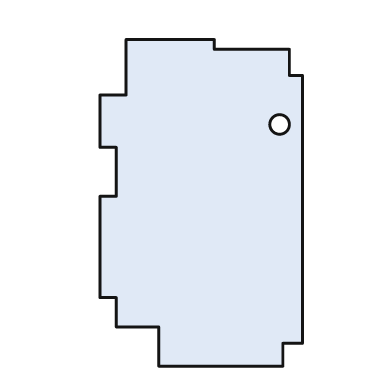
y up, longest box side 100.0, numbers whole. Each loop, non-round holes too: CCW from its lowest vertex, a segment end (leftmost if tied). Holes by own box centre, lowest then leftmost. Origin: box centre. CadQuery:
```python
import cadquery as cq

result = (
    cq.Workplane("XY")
    .moveTo(-13.0, -50.0)
    .lineTo(25.0, -50.0)
    .lineTo(25.0, -43.0)
    .lineTo(31.0, -43.0)
    .lineTo(31.0, 39.0)
    .lineTo(27.0, 39.0)
    .lineTo(27.0, 47.0)
    .lineTo(4.0, 47.0)
    .lineTo(4.0, 50.0)
    .lineTo(-23.0, 50.0)
    .lineTo(-23.0, 33.0)
    .lineTo(-31.0, 33.0)
    .lineTo(-31.0, 17.0)
    .lineTo(-26.0, 17.0)
    .lineTo(-26.0, 2.0)
    .lineTo(-31.0, 2.0)
    .lineTo(-31.0, -29.0)
    .lineTo(-26.0, -29.0)
    .lineTo(-26.0, -38.0)
    .lineTo(-13.0, -38.0)
    .close()
    .moveTo(24.0, 24.0)
    .circle(3.0)
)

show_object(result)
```